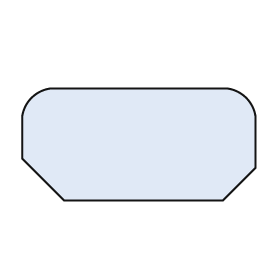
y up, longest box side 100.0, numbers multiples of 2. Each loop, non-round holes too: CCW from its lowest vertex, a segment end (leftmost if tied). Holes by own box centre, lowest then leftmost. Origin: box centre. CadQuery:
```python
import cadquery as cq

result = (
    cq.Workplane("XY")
    .moveTo(-32.0, -24.0)
    .lineTo(36.0, -24.0)
    .lineTo(50.0, -10.0)
    .lineTo(50.0, 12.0)
    .threePointArc((46.0, 20.0), (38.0, 24.0))
    .lineTo(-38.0, 24.0)
    .threePointArc((-46.0, 20.0), (-50.0, 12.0))
    .lineTo(-50.0, -6.0)
    .close()
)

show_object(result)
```